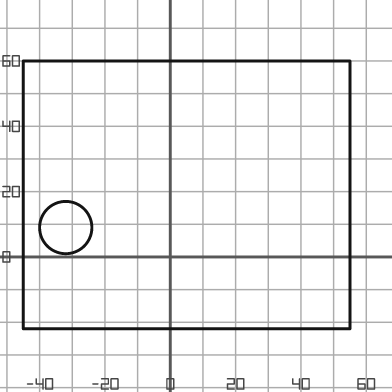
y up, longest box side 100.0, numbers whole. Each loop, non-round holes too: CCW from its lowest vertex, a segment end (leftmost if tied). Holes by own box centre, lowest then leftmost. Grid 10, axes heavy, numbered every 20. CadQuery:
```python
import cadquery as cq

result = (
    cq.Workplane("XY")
    .moveTo(-45.0, -22.0)
    .lineTo(55.0, -22.0)
    .lineTo(55.0, 60.0)
    .lineTo(-45.0, 60.0)
    .close()
    .moveTo(-32.0, 9.0)
    .circle(8.0)
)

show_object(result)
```